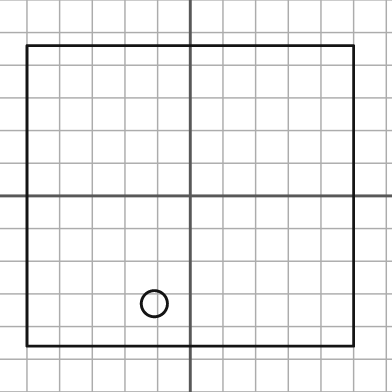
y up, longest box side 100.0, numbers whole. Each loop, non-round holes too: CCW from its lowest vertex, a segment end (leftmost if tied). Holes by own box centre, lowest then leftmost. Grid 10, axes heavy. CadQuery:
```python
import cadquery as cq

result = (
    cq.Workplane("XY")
    .moveTo(-50.0, -46.0)
    .lineTo(50.0, -46.0)
    .lineTo(50.0, 46.0)
    .lineTo(-50.0, 46.0)
    .close()
    .moveTo(-11.0, -33.0)
    .circle(4.0)
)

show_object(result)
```